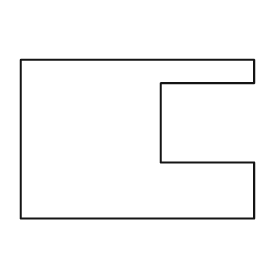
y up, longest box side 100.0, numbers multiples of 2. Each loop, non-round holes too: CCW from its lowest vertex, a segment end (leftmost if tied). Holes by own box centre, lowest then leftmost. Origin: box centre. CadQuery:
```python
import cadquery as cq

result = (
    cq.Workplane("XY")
    .moveTo(-50.0, -34.0)
    .lineTo(50.0, -34.0)
    .lineTo(50.0, -10.0)
    .lineTo(10.0, -10.0)
    .lineTo(10.0, 24.0)
    .lineTo(50.0, 24.0)
    .lineTo(50.0, 34.0)
    .lineTo(-50.0, 34.0)
    .close()
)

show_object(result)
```